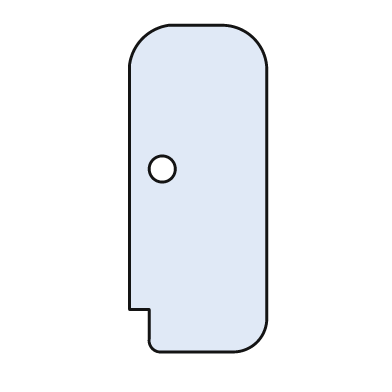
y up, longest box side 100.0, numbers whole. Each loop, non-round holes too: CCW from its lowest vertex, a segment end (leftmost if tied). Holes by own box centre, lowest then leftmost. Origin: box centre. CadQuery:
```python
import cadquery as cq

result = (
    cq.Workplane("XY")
    .moveTo(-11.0, -50.0)
    .lineTo(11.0, -50.0)
    .threePointArc((18.0, -47.0), (21.0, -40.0))
    .lineTo(21.0, 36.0)
    .threePointArc((17.0, 46.0), (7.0, 50.0))
    .lineTo(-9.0, 50.0)
    .threePointArc((-17.0, 46.0), (-21.0, 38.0))
    .lineTo(-21.0, -37.0)
    .lineTo(-15.0, -37.0)
    .lineTo(-15.0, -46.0)
    .threePointArc((-14.0, -49.0), (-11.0, -50.0))
    .close()
    .moveTo(-11.0, 6.0)
    .circle(4.0)
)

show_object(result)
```